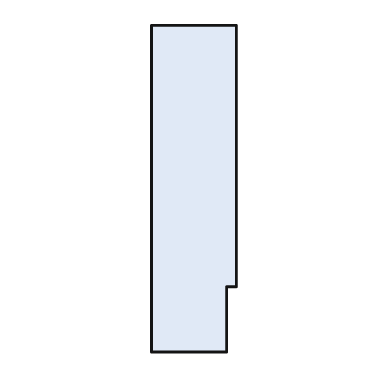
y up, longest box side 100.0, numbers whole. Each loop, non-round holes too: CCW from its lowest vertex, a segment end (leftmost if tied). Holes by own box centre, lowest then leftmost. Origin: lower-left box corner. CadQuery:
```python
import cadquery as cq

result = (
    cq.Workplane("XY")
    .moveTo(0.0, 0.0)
    .lineTo(23.0, 0.0)
    .lineTo(23.0, 20.0)
    .lineTo(26.0, 20.0)
    .lineTo(26.0, 100.0)
    .lineTo(0.0, 100.0)
    .close()
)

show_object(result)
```